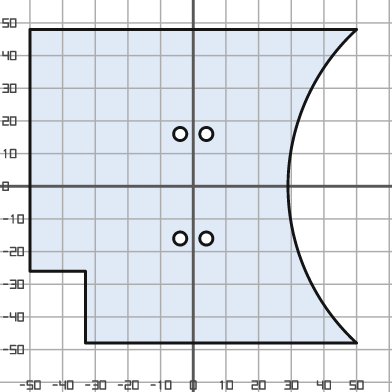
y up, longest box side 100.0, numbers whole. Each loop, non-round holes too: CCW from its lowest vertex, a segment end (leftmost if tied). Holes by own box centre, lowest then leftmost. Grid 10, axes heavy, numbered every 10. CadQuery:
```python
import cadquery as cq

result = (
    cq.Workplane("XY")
    .moveTo(-33.0, -48.0)
    .lineTo(50.0, -48.0)
    .threePointArc((29.0, 0.0), (50.0, 48.0))
    .lineTo(-50.0, 48.0)
    .lineTo(-50.0, -26.0)
    .lineTo(-33.0, -26.0)
    .close()
    .moveTo(-4.0, -16.0)
    .circle(2.0)
    .moveTo(4.0, -16.0)
    .circle(2.0)
    .moveTo(-4.0, 16.0)
    .circle(2.0)
    .moveTo(4.0, 16.0)
    .circle(2.0)
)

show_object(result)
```